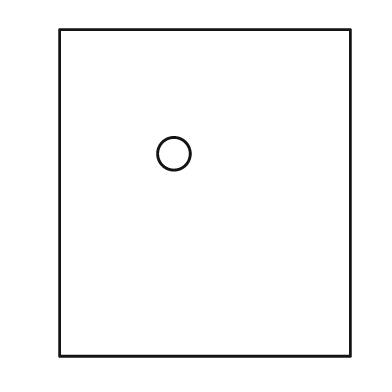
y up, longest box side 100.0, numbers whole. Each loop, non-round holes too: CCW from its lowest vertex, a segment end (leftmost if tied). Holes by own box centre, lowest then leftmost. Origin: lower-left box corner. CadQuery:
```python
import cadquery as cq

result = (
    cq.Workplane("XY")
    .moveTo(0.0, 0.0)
    .lineTo(89.0, 0.0)
    .lineTo(89.0, 100.0)
    .lineTo(0.0, 100.0)
    .close()
    .moveTo(35.0, 62.0)
    .circle(5.0)
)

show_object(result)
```